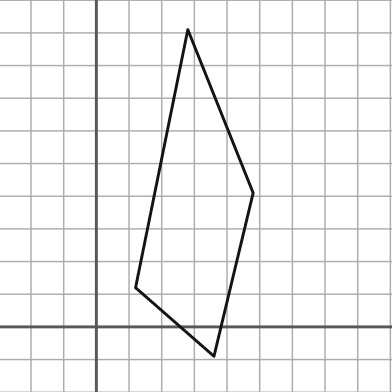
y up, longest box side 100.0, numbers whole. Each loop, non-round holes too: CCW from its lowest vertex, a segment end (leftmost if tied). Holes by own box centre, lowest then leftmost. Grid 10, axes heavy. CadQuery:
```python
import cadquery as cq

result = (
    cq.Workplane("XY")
    .moveTo(36.0, -9.0)
    .lineTo(48.0, 41.0)
    .lineTo(28.0, 91.0)
    .lineTo(12.0, 12.0)
    .close()
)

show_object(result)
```